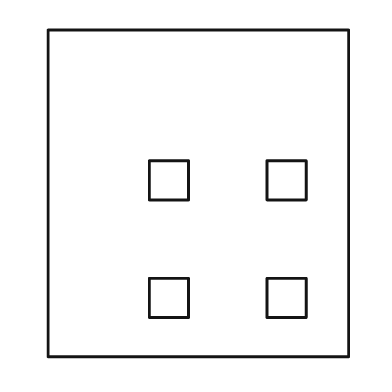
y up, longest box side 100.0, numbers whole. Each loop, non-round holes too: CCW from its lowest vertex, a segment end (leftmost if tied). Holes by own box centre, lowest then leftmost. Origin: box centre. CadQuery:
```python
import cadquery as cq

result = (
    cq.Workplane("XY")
    .moveTo(-46.0, -50.0)
    .lineTo(46.0, -50.0)
    .lineTo(46.0, 50.0)
    .lineTo(-46.0, 50.0)
    .close()
    .moveTo(-15.0, -38.0)
    .lineTo(-3.0, -38.0)
    .lineTo(-3.0, -26.0)
    .lineTo(-15.0, -26.0)
    .close()
    .moveTo(21.0, -38.0)
    .lineTo(33.0, -38.0)
    .lineTo(33.0, -26.0)
    .lineTo(21.0, -26.0)
    .close()
    .moveTo(-15.0, -2.0)
    .lineTo(-3.0, -2.0)
    .lineTo(-3.0, 10.0)
    .lineTo(-15.0, 10.0)
    .close()
    .moveTo(21.0, -2.0)
    .lineTo(33.0, -2.0)
    .lineTo(33.0, 10.0)
    .lineTo(21.0, 10.0)
    .close()
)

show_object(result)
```